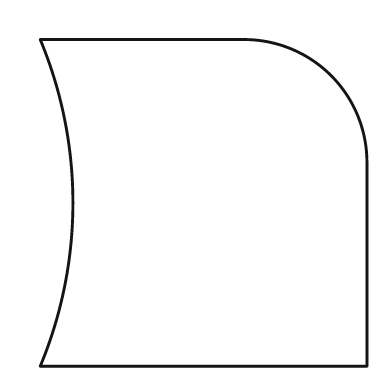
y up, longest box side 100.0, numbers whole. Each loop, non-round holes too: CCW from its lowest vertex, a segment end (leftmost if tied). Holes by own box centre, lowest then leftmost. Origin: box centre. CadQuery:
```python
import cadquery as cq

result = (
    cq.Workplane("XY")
    .moveTo(-50.0, -50.0)
    .lineTo(50.0, -50.0)
    .lineTo(50.0, 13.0)
    .threePointArc((39.0, 39.0), (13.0, 50.0))
    .lineTo(-50.0, 50.0)
    .threePointArc((-40.0, 0.0), (-50.0, -50.0))
    .close()
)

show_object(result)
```